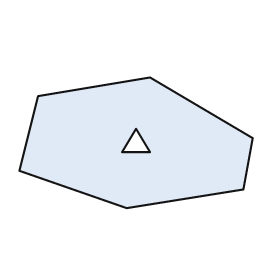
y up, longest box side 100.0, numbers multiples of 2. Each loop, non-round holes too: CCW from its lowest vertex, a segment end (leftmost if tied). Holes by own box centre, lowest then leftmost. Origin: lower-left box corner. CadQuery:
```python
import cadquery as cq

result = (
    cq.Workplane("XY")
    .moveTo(46.0, 0.0)
    .lineTo(96.0, 8.0)
    .lineTo(100.0, 30.0)
    .lineTo(56.0, 56.0)
    .lineTo(8.0, 48.0)
    .lineTo(0.0, 16.0)
    .close()
    .moveTo(44.0, 24.0)
    .lineTo(56.0, 24.0)
    .lineTo(50.0, 34.0)
    .close()
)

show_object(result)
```